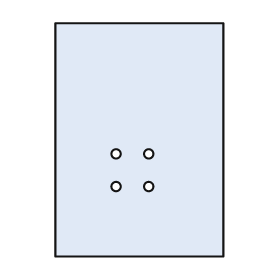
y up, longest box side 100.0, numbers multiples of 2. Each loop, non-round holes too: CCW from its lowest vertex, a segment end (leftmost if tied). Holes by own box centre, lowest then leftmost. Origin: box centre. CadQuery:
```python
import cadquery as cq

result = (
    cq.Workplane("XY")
    .moveTo(-36.0, -50.0)
    .lineTo(36.0, -50.0)
    .lineTo(36.0, 50.0)
    .lineTo(-36.0, 50.0)
    .close()
    .moveTo(-10.0, -20.0)
    .circle(2.0)
    .moveTo(4.0, -20.0)
    .circle(2.0)
    .moveTo(-10.0, -6.0)
    .circle(2.0)
    .moveTo(4.0, -6.0)
    .circle(2.0)
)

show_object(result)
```